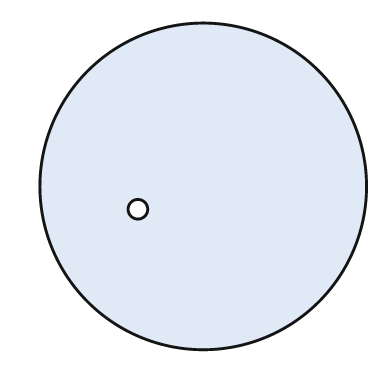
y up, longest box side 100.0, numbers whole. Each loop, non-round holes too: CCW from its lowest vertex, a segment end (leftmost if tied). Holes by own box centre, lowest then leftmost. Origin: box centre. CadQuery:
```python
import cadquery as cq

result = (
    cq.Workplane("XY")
    .moveTo(0.0, 0.0)
    .circle(50.0)
    .moveTo(-20.0, -7.0)
    .circle(3.0)
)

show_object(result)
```